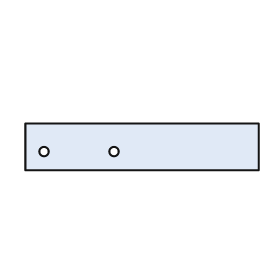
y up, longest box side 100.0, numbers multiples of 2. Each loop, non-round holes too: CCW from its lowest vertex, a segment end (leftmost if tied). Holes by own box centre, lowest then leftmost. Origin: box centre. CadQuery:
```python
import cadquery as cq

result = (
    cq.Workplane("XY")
    .moveTo(-50.0, -10.0)
    .lineTo(50.0, -10.0)
    .lineTo(50.0, 10.0)
    .lineTo(-50.0, 10.0)
    .close()
    .moveTo(-42.0, -2.0)
    .circle(2.0)
    .moveTo(-12.0, -2.0)
    .circle(2.0)
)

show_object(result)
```